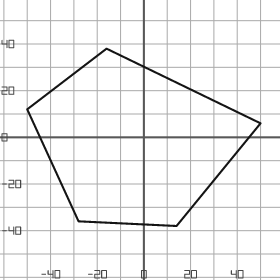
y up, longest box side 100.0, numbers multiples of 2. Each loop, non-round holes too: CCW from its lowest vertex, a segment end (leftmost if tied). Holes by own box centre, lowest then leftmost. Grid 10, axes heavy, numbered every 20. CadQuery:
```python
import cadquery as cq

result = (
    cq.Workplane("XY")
    .moveTo(14.0, -38.0)
    .lineTo(50.0, 6.0)
    .lineTo(-16.0, 38.0)
    .lineTo(-50.0, 12.0)
    .lineTo(-28.0, -36.0)
    .close()
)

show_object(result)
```